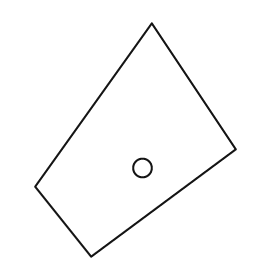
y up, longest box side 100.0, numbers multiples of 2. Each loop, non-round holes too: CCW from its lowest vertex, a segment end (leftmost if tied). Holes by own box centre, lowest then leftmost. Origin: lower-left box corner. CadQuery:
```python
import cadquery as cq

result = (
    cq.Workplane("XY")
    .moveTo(24.0, 0.0)
    .lineTo(86.0, 46.0)
    .lineTo(50.0, 100.0)
    .lineTo(0.0, 30.0)
    .close()
    .moveTo(46.0, 38.0)
    .circle(4.0)
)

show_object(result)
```